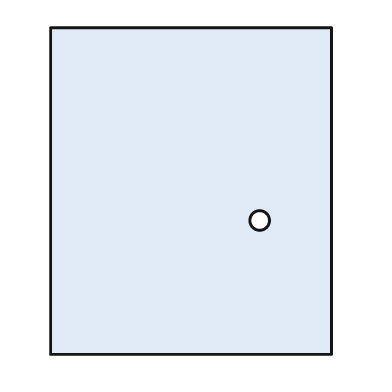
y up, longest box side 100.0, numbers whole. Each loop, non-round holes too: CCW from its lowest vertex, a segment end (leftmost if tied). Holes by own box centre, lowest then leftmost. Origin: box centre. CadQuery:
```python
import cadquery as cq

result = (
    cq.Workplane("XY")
    .moveTo(-43.0, -50.0)
    .lineTo(43.0, -50.0)
    .lineTo(43.0, 50.0)
    .lineTo(-43.0, 50.0)
    .close()
    .moveTo(21.0, -9.0)
    .circle(3.0)
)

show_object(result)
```